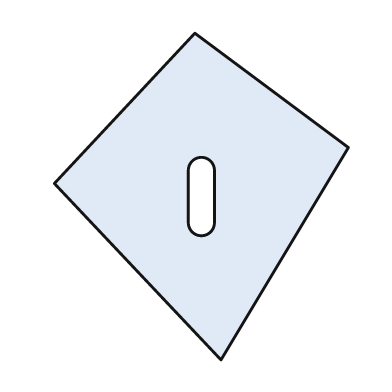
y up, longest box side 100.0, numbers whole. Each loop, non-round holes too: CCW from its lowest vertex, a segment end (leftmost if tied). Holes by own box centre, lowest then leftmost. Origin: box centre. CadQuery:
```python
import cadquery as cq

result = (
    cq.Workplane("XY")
    .moveTo(6.0, -50.0)
    .lineTo(45.0, 15.0)
    .lineTo(-2.0, 50.0)
    .lineTo(-45.0, 4.0)
    .close()
    .moveTo(-4.0, -8.0)
    .threePointArc((0.0, -12.0), (4.0, -8.0))
    .lineTo(4.0, 8.0)
    .threePointArc((0.0, 12.0), (-4.0, 8.0))
    .close()
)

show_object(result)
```